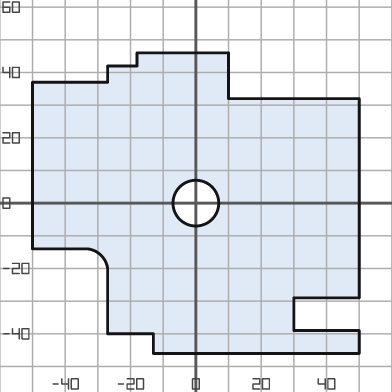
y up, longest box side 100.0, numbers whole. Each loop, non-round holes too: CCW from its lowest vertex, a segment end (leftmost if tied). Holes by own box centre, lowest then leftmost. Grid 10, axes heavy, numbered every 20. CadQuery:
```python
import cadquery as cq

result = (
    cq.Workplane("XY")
    .moveTo(-13.0, -46.0)
    .lineTo(50.0, -46.0)
    .lineTo(50.0, -39.0)
    .lineTo(30.0, -39.0)
    .lineTo(30.0, -29.0)
    .lineTo(50.0, -29.0)
    .lineTo(50.0, 32.0)
    .lineTo(10.0, 32.0)
    .lineTo(10.0, 46.0)
    .lineTo(-18.0, 46.0)
    .lineTo(-18.0, 42.0)
    .lineTo(-27.0, 42.0)
    .lineTo(-27.0, 37.0)
    .lineTo(-50.0, 37.0)
    .lineTo(-50.0, -14.0)
    .lineTo(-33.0, -14.0)
    .threePointArc((-29.0, -16.0), (-27.0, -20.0))
    .lineTo(-27.0, -40.0)
    .lineTo(-13.0, -40.0)
    .close()
    .moveTo(0.0, 0.0)
    .circle(7.0)
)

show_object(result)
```